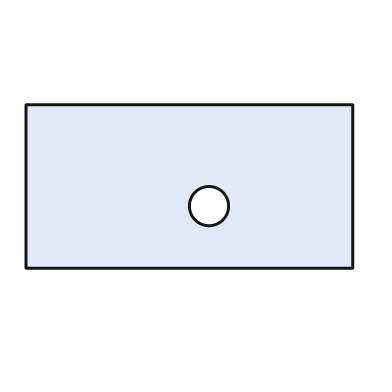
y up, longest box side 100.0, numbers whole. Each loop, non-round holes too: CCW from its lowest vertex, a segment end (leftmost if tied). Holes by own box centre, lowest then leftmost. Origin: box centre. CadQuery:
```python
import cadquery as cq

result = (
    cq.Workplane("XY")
    .moveTo(-50.0, -25.0)
    .lineTo(50.0, -25.0)
    .lineTo(50.0, 25.0)
    .lineTo(-50.0, 25.0)
    .close()
    .moveTo(6.0, -6.0)
    .circle(6.0)
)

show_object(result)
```